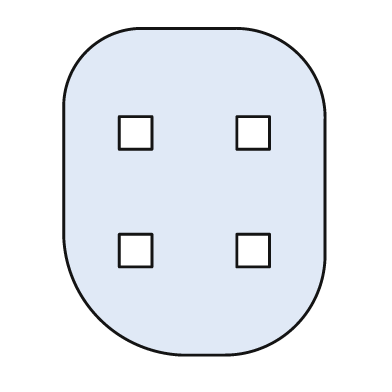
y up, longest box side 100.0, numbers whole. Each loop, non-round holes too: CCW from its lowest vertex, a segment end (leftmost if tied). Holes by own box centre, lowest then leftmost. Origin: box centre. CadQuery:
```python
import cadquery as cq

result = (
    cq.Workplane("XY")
    .moveTo(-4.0, -50.0)
    .lineTo(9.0, -50.0)
    .threePointArc((31.0, -41.0), (40.0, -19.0))
    .lineTo(40.0, 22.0)
    .threePointArc((32.0, 42.0), (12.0, 50.0))
    .lineTo(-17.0, 50.0)
    .threePointArc((-33.0, 43.0), (-40.0, 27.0))
    .lineTo(-40.0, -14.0)
    .threePointArc((-29.0, -39.0), (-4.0, -50.0))
    .close()
    .moveTo(-23.0, -23.0)
    .lineTo(-13.0, -23.0)
    .lineTo(-13.0, -13.0)
    .lineTo(-23.0, -13.0)
    .close()
    .moveTo(13.0, -23.0)
    .lineTo(23.0, -23.0)
    .lineTo(23.0, -13.0)
    .lineTo(13.0, -13.0)
    .close()
    .moveTo(-23.0, 13.0)
    .lineTo(-13.0, 13.0)
    .lineTo(-13.0, 23.0)
    .lineTo(-23.0, 23.0)
    .close()
    .moveTo(13.0, 13.0)
    .lineTo(23.0, 13.0)
    .lineTo(23.0, 23.0)
    .lineTo(13.0, 23.0)
    .close()
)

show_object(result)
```